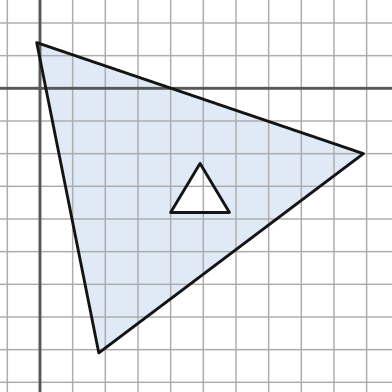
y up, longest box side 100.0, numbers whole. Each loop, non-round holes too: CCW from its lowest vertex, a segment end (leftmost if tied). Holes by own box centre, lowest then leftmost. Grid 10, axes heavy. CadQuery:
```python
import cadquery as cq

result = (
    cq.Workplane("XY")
    .moveTo(18.0, -81.0)
    .lineTo(99.0, -20.0)
    .lineTo(-1.0, 14.0)
    .close()
    .moveTo(40.0, -38.0)
    .lineTo(58.0, -38.0)
    .lineTo(49.0, -23.0)
    .close()
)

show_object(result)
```